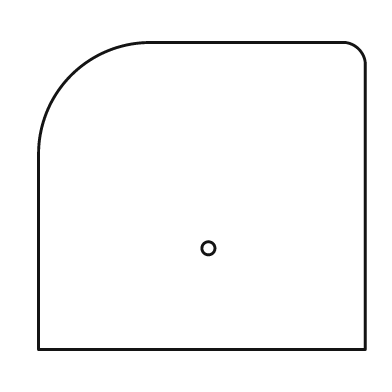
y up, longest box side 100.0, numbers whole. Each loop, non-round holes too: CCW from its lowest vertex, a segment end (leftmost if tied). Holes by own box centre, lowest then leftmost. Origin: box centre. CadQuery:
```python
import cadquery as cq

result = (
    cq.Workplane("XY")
    .moveTo(-50.0, -47.0)
    .lineTo(50.0, -47.0)
    .lineTo(50.0, 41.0)
    .threePointArc((48.0, 45.0), (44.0, 47.0))
    .lineTo(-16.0, 47.0)
    .threePointArc((-40.0, 37.0), (-50.0, 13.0))
    .close()
    .moveTo(2.0, -16.0)
    .circle(2.0)
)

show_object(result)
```